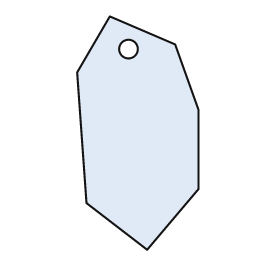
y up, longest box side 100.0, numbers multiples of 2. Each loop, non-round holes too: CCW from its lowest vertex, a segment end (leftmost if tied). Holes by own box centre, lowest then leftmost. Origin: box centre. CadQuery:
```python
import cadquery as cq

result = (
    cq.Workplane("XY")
    .moveTo(4.0, -50.0)
    .lineTo(26.0, -24.0)
    .lineTo(26.0, 10.0)
    .lineTo(16.0, 38.0)
    .lineTo(-12.0, 50.0)
    .lineTo(-26.0, 26.0)
    .lineTo(-22.0, -30.0)
    .close()
    .moveTo(-4.0, 36.0)
    .circle(4.0)
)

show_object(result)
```